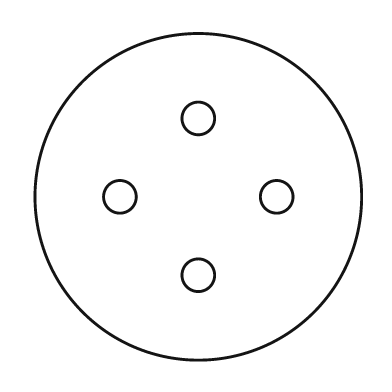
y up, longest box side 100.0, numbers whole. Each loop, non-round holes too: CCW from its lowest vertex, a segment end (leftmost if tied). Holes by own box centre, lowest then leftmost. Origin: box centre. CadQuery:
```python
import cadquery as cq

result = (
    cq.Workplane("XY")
    .moveTo(0.0, 0.0)
    .circle(50.0)
    .moveTo(0.0, -24.0)
    .circle(5.0)
    .moveTo(-24.0, 0.0)
    .circle(5.0)
    .moveTo(24.0, 0.0)
    .circle(5.0)
    .moveTo(0.0, 24.0)
    .circle(5.0)
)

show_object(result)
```